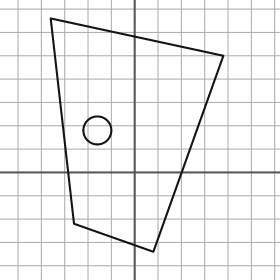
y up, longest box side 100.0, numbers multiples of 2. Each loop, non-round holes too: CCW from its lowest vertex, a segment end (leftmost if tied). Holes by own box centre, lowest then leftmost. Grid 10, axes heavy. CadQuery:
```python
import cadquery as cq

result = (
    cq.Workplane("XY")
    .moveTo(8.0, -34.0)
    .lineTo(38.0, 50.0)
    .lineTo(-36.0, 66.0)
    .lineTo(-26.0, -22.0)
    .close()
    .moveTo(-16.0, 18.0)
    .circle(6.0)
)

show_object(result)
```